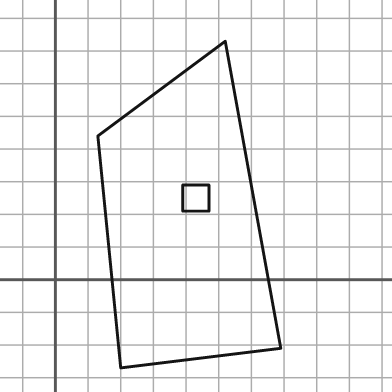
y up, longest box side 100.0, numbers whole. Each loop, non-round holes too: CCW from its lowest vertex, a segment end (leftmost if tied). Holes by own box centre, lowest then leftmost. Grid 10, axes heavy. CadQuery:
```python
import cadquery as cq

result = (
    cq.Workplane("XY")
    .moveTo(20.0, -27.0)
    .lineTo(69.0, -21.0)
    .lineTo(52.0, 73.0)
    .lineTo(13.0, 44.0)
    .close()
    .moveTo(39.0, 21.0)
    .lineTo(47.0, 21.0)
    .lineTo(47.0, 29.0)
    .lineTo(39.0, 29.0)
    .close()
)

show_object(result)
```